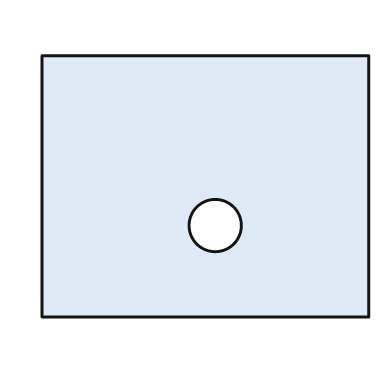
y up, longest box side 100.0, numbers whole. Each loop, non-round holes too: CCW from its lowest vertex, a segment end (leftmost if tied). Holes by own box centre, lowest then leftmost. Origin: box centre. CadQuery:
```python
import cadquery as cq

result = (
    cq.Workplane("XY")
    .moveTo(-50.0, -40.0)
    .lineTo(50.0, -40.0)
    .lineTo(50.0, 40.0)
    .lineTo(-50.0, 40.0)
    .close()
    .moveTo(3.0, -12.0)
    .circle(8.0)
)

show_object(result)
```